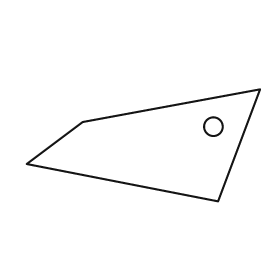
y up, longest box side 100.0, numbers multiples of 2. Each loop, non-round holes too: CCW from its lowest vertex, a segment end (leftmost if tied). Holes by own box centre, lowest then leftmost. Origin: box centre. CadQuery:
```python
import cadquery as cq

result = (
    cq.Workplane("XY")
    .moveTo(32.0, -24.0)
    .lineTo(50.0, 24.0)
    .lineTo(-26.0, 10.0)
    .lineTo(-50.0, -8.0)
    .close()
    .moveTo(30.0, 8.0)
    .circle(4.0)
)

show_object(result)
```